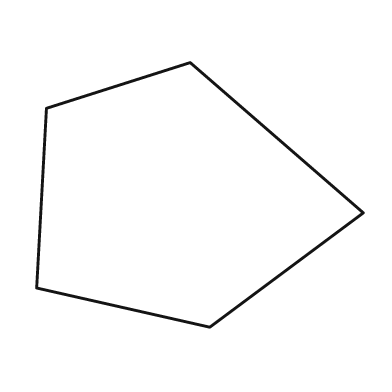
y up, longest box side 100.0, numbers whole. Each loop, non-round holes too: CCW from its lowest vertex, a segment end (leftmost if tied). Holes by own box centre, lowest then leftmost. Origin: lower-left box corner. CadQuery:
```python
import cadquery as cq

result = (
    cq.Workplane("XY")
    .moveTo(53.0, 0.0)
    .lineTo(100.0, 35.0)
    .lineTo(47.0, 81.0)
    .lineTo(3.0, 67.0)
    .lineTo(0.0, 12.0)
    .close()
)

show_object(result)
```